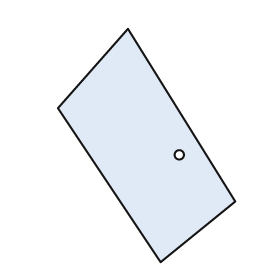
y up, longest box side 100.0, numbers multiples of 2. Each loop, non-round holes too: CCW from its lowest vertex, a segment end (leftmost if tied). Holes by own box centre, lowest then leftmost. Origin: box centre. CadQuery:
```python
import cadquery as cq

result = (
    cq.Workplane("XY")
    .moveTo(6.0, -50.0)
    .lineTo(38.0, -24.0)
    .lineTo(-8.0, 50.0)
    .lineTo(-38.0, 16.0)
    .close()
    .moveTo(14.0, -4.0)
    .circle(2.0)
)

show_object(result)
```